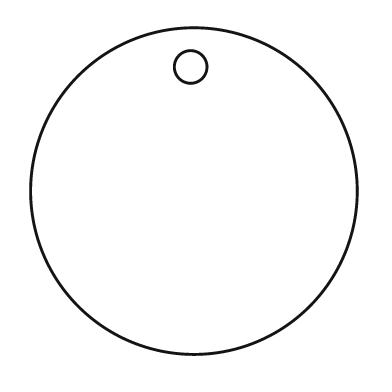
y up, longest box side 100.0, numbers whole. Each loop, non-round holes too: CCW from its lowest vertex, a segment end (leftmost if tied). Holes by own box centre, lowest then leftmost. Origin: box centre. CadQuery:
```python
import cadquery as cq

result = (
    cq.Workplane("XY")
    .moveTo(0.0, 0.0)
    .circle(50.0)
    .moveTo(-1.0, 38.0)
    .circle(5.0)
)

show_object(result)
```